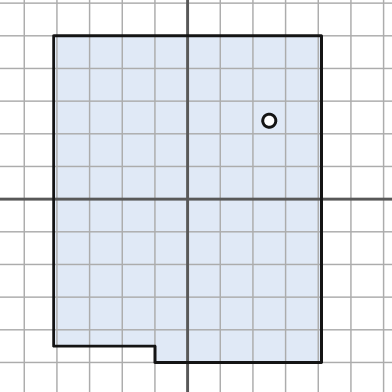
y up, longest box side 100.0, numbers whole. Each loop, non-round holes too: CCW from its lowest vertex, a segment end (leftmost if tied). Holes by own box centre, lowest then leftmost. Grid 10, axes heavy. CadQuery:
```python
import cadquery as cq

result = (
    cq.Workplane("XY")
    .moveTo(-10.0, -50.0)
    .lineTo(41.0, -50.0)
    .lineTo(41.0, 50.0)
    .lineTo(-41.0, 50.0)
    .lineTo(-41.0, -45.0)
    .lineTo(-10.0, -45.0)
    .close()
    .moveTo(25.0, 24.0)
    .circle(2.0)
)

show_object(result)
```